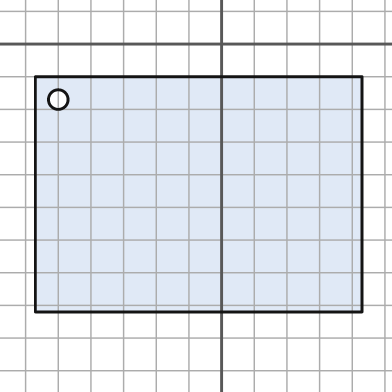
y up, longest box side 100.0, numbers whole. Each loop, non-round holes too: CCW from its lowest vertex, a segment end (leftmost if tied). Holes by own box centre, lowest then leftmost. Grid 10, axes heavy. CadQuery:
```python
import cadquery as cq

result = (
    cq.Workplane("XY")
    .moveTo(-57.0, -82.0)
    .lineTo(43.0, -82.0)
    .lineTo(43.0, -10.0)
    .lineTo(-57.0, -10.0)
    .close()
    .moveTo(-50.0, -17.0)
    .circle(3.0)
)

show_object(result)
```